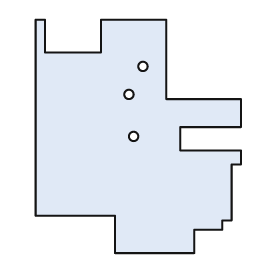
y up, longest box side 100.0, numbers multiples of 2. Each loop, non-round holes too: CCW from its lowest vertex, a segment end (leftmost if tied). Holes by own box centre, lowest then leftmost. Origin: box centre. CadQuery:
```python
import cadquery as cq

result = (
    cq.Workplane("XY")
    .moveTo(-10.0, -50.0)
    .lineTo(24.0, -50.0)
    .lineTo(24.0, -40.0)
    .lineTo(36.0, -40.0)
    .lineTo(36.0, -36.0)
    .lineTo(40.0, -36.0)
    .lineTo(40.0, -12.0)
    .lineTo(44.0, -12.0)
    .lineTo(44.0, -6.0)
    .lineTo(18.0, -6.0)
    .lineTo(18.0, 4.0)
    .lineTo(44.0, 4.0)
    .lineTo(44.0, 16.0)
    .lineTo(12.0, 16.0)
    .lineTo(12.0, 50.0)
    .lineTo(-16.0, 50.0)
    .lineTo(-16.0, 36.0)
    .lineTo(-40.0, 36.0)
    .lineTo(-40.0, 50.0)
    .lineTo(-44.0, 50.0)
    .lineTo(-44.0, -34.0)
    .lineTo(-10.0, -34.0)
    .close()
    .moveTo(-2.0, 0.0)
    .circle(2.0)
    .moveTo(-4.0, 18.0)
    .circle(2.0)
    .moveTo(2.0, 30.0)
    .circle(2.0)
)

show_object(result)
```